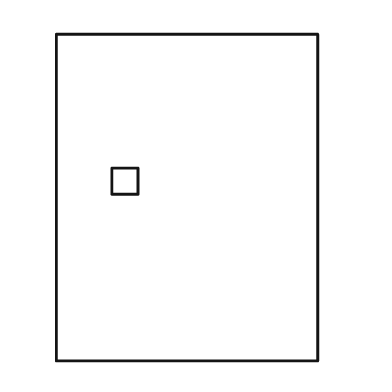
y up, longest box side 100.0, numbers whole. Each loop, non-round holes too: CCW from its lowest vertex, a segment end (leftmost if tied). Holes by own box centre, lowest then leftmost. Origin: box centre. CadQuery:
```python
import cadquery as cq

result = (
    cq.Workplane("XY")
    .moveTo(-40.0, -50.0)
    .lineTo(40.0, -50.0)
    .lineTo(40.0, 50.0)
    .lineTo(-40.0, 50.0)
    .close()
    .moveTo(-23.0, 1.0)
    .lineTo(-15.0, 1.0)
    .lineTo(-15.0, 9.0)
    .lineTo(-23.0, 9.0)
    .close()
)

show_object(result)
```